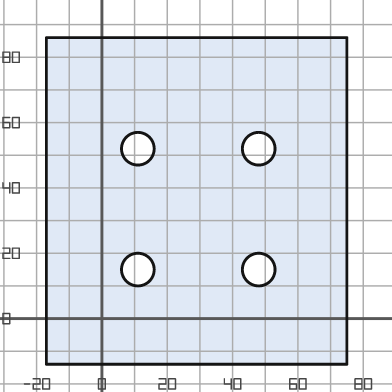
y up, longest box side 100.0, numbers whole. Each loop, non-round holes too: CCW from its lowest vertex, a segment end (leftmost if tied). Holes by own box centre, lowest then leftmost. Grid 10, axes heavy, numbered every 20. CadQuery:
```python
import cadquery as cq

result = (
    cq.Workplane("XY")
    .moveTo(-17.0, -14.0)
    .lineTo(75.0, -14.0)
    .lineTo(75.0, 86.0)
    .lineTo(-17.0, 86.0)
    .close()
    .moveTo(11.0, 15.0)
    .circle(5.0)
    .moveTo(48.0, 15.0)
    .circle(5.0)
    .moveTo(11.0, 52.0)
    .circle(5.0)
    .moveTo(48.0, 52.0)
    .circle(5.0)
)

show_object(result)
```